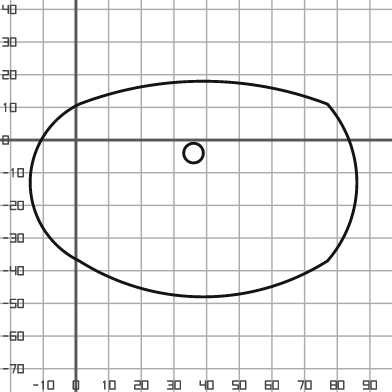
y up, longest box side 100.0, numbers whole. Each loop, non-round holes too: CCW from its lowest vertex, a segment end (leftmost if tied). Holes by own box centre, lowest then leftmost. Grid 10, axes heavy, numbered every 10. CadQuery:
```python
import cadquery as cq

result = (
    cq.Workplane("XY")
    .moveTo(1.0, -37.0)
    .threePointArc((39.0, -48.0), (77.0, -37.0))
    .threePointArc((86.0, -13.0), (77.0, 11.0))
    .threePointArc((39.0, 18.0), (1.0, 11.0))
    .threePointArc((-14.0, -13.0), (1.0, -37.0))
    .close()
    .moveTo(36.0, -4.0)
    .circle(3.0)
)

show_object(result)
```